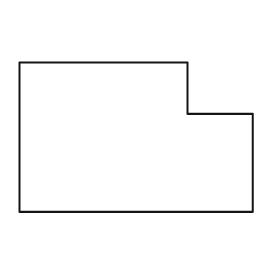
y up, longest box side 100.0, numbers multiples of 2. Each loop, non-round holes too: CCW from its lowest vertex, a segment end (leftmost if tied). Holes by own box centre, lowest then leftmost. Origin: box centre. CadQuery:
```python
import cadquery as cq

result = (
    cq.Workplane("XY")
    .moveTo(-50.0, -32.0)
    .lineTo(50.0, -32.0)
    .lineTo(50.0, 10.0)
    .lineTo(22.0, 10.0)
    .lineTo(22.0, 32.0)
    .lineTo(-50.0, 32.0)
    .close()
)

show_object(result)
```